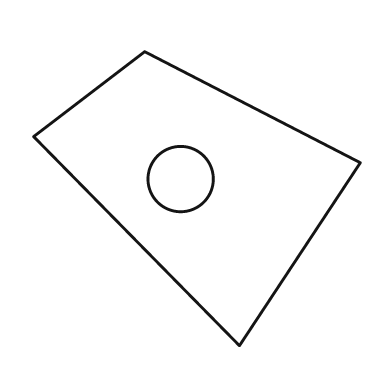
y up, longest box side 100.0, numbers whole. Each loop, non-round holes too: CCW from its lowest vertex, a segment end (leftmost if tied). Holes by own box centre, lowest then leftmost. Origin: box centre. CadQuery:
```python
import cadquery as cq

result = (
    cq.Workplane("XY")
    .moveTo(13.0, -45.0)
    .lineTo(50.0, 11.0)
    .lineTo(-16.0, 45.0)
    .lineTo(-50.0, 19.0)
    .close()
    .moveTo(-5.0, 6.0)
    .circle(10.0)
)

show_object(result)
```